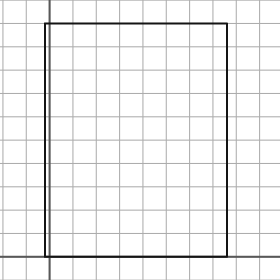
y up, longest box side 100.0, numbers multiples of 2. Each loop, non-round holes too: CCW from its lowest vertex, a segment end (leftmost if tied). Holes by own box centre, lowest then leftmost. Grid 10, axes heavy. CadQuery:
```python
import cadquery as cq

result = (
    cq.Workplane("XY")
    .moveTo(-2.0, 0.0)
    .lineTo(76.0, 0.0)
    .lineTo(76.0, 100.0)
    .lineTo(-2.0, 100.0)
    .close()
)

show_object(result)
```